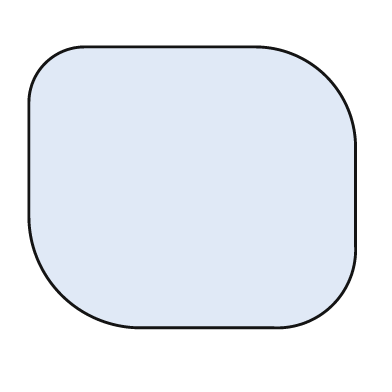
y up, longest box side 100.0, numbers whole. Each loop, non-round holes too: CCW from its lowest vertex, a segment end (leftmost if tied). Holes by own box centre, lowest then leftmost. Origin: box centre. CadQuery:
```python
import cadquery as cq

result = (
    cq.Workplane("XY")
    .moveTo(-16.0, -43.0)
    .lineTo(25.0, -43.0)
    .threePointArc((43.0, -36.0), (50.0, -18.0))
    .lineTo(50.0, 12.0)
    .threePointArc((41.0, 34.0), (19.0, 43.0))
    .lineTo(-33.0, 43.0)
    .threePointArc((-45.0, 38.0), (-50.0, 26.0))
    .lineTo(-50.0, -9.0)
    .threePointArc((-40.0, -33.0), (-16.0, -43.0))
    .close()
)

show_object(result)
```